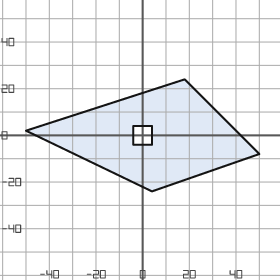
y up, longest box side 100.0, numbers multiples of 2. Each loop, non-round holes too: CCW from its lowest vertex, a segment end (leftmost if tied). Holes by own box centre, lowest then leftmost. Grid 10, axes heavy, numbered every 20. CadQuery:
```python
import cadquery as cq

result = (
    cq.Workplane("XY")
    .moveTo(4.0, -24.0)
    .lineTo(50.0, -8.0)
    .lineTo(18.0, 24.0)
    .lineTo(-50.0, 2.0)
    .close()
    .moveTo(-4.0, -4.0)
    .lineTo(4.0, -4.0)
    .lineTo(4.0, 4.0)
    .lineTo(-4.0, 4.0)
    .close()
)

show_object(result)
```